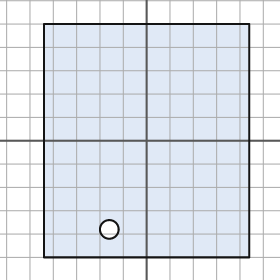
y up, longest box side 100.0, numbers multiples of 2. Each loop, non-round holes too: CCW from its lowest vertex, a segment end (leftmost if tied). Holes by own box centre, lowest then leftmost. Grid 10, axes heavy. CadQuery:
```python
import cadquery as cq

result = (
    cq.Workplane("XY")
    .moveTo(-44.0, -50.0)
    .lineTo(44.0, -50.0)
    .lineTo(44.0, 50.0)
    .lineTo(-44.0, 50.0)
    .close()
    .moveTo(-16.0, -38.0)
    .circle(4.0)
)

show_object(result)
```